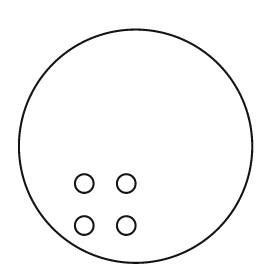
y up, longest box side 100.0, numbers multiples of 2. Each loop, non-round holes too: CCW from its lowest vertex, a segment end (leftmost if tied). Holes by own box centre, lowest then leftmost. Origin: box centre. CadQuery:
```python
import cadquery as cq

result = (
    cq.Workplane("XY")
    .moveTo(0.0, 0.0)
    .circle(50.0)
    .moveTo(-22.0, -34.0)
    .circle(4.0)
    .moveTo(-4.0, -34.0)
    .circle(4.0)
    .moveTo(-22.0, -16.0)
    .circle(4.0)
    .moveTo(-4.0, -16.0)
    .circle(4.0)
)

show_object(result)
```